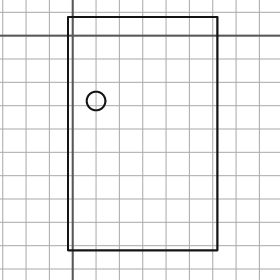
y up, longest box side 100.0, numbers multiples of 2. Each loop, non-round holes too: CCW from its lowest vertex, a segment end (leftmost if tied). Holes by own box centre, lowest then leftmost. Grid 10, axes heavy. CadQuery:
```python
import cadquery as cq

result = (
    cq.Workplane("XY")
    .moveTo(-2.0, -92.0)
    .lineTo(62.0, -92.0)
    .lineTo(62.0, 8.0)
    .lineTo(-2.0, 8.0)
    .close()
    .moveTo(10.0, -28.0)
    .circle(4.0)
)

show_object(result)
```